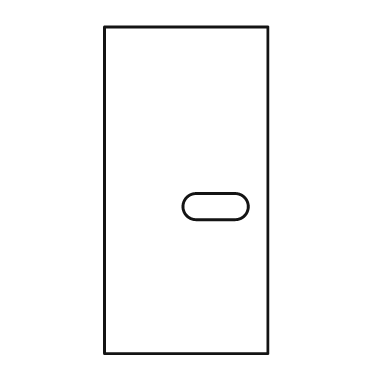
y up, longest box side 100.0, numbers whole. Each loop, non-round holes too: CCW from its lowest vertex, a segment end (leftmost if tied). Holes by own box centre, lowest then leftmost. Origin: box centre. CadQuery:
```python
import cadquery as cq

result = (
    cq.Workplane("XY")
    .moveTo(-25.0, -50.0)
    .lineTo(25.0, -50.0)
    .lineTo(25.0, 50.0)
    .lineTo(-25.0, 50.0)
    .close()
    .moveTo(3.0, -9.0)
    .lineTo(15.0, -9.0)
    .threePointArc((19.0, -5.0), (15.0, -1.0))
    .lineTo(3.0, -1.0)
    .threePointArc((-1.0, -5.0), (3.0, -9.0))
    .close()
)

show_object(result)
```